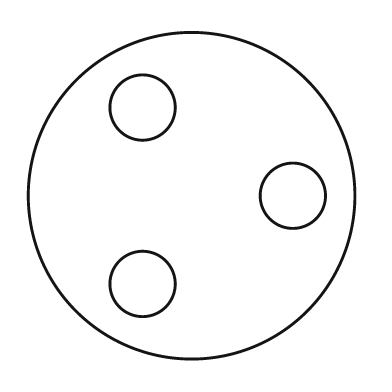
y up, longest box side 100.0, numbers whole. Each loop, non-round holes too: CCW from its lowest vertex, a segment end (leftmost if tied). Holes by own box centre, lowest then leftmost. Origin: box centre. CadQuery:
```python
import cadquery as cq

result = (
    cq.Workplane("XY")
    .moveTo(0.0, 0.0)
    .circle(50.0)
    .moveTo(-15.0, -27.0)
    .circle(10.0)
    .moveTo(31.0, 0.0)
    .circle(10.0)
    .moveTo(-15.0, 27.0)
    .circle(10.0)
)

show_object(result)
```